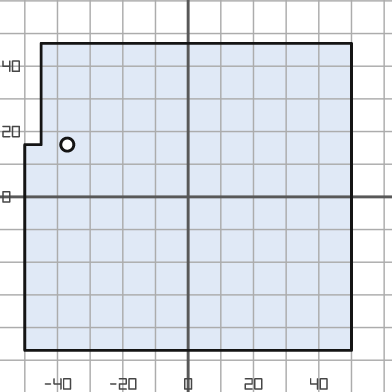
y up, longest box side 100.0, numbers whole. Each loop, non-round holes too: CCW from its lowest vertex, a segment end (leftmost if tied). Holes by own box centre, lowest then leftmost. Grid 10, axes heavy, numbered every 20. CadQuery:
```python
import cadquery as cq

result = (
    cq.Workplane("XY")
    .moveTo(-50.0, -47.0)
    .lineTo(50.0, -47.0)
    .lineTo(50.0, 47.0)
    .lineTo(-45.0, 47.0)
    .lineTo(-45.0, 16.0)
    .lineTo(-50.0, 16.0)
    .close()
    .moveTo(-37.0, 16.0)
    .circle(2.0)
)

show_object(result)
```